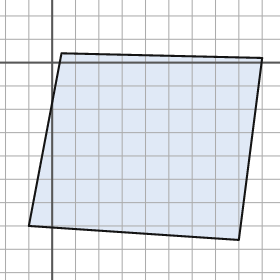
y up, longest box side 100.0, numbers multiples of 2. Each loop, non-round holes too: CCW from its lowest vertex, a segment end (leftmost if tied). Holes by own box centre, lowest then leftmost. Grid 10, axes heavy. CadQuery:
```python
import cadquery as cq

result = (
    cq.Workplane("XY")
    .moveTo(80.0, -76.0)
    .lineTo(90.0, 2.0)
    .lineTo(4.0, 4.0)
    .lineTo(-10.0, -70.0)
    .close()
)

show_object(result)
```